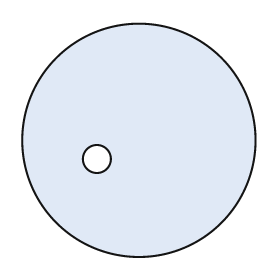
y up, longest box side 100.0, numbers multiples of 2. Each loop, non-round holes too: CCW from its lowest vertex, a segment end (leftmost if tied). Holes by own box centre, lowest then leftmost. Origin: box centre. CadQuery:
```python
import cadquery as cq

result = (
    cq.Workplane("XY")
    .moveTo(0.0, 0.0)
    .circle(50.0)
    .moveTo(-18.0, -8.0)
    .circle(6.0)
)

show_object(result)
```